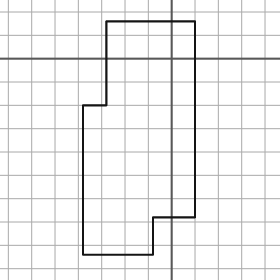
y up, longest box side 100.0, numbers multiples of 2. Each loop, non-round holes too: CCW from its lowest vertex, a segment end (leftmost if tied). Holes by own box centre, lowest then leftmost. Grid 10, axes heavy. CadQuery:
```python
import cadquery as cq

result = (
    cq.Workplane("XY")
    .moveTo(-38.0, -84.0)
    .lineTo(-8.0, -84.0)
    .lineTo(-8.0, -68.0)
    .lineTo(10.0, -68.0)
    .lineTo(10.0, 16.0)
    .lineTo(-28.0, 16.0)
    .lineTo(-28.0, -20.0)
    .lineTo(-38.0, -20.0)
    .close()
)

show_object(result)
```